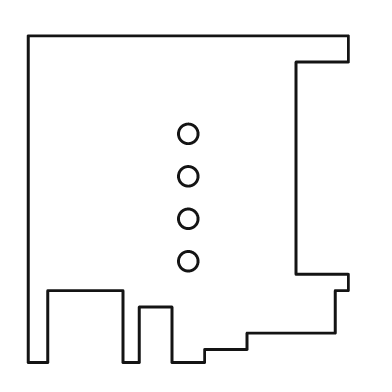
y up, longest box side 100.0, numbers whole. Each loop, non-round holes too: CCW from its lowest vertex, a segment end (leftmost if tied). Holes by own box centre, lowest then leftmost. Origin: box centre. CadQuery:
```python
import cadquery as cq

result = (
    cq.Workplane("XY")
    .moveTo(-49.0, -50.0)
    .lineTo(-43.0, -50.0)
    .lineTo(-43.0, -28.0)
    .lineTo(-20.0, -28.0)
    .lineTo(-20.0, -50.0)
    .lineTo(-15.0, -50.0)
    .lineTo(-15.0, -33.0)
    .lineTo(-5.0, -33.0)
    .lineTo(-5.0, -50.0)
    .lineTo(5.0, -50.0)
    .lineTo(5.0, -46.0)
    .lineTo(18.0, -46.0)
    .lineTo(18.0, -41.0)
    .lineTo(45.0, -41.0)
    .lineTo(45.0, -28.0)
    .lineTo(49.0, -28.0)
    .lineTo(49.0, -23.0)
    .lineTo(33.0, -23.0)
    .lineTo(33.0, 42.0)
    .lineTo(49.0, 42.0)
    .lineTo(49.0, 50.0)
    .lineTo(-49.0, 50.0)
    .close()
    .moveTo(0.0, -19.0)
    .circle(3.0)
    .moveTo(0.0, -6.0)
    .circle(3.0)
    .moveTo(0.0, 7.0)
    .circle(3.0)
    .moveTo(0.0, 20.0)
    .circle(3.0)
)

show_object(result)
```